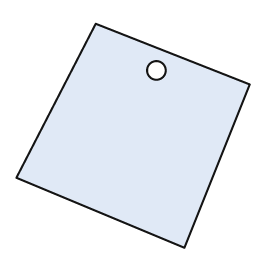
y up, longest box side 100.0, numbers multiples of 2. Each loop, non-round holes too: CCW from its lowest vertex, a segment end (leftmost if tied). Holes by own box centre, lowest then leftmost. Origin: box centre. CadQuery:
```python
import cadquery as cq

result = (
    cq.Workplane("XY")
    .moveTo(22.0, -48.0)
    .lineTo(50.0, 22.0)
    .lineTo(-16.0, 48.0)
    .lineTo(-50.0, -18.0)
    .close()
    .moveTo(10.0, 28.0)
    .circle(4.0)
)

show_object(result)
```